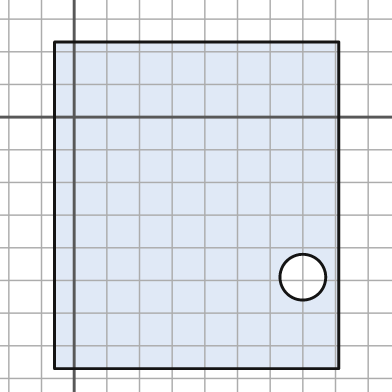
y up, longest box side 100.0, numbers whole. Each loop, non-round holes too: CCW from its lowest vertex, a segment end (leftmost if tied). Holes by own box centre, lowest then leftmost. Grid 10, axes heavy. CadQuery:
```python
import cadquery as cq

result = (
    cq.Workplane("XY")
    .moveTo(-6.0, -77.0)
    .lineTo(81.0, -77.0)
    .lineTo(81.0, 23.0)
    .lineTo(-6.0, 23.0)
    .close()
    .moveTo(70.0, -49.0)
    .circle(7.0)
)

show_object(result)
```